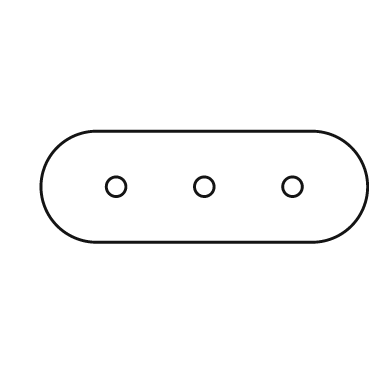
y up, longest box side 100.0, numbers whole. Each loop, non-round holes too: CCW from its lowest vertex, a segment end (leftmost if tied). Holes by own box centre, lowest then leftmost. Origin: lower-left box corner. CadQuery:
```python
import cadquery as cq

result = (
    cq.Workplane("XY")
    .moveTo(17.0, 0.0)
    .lineTo(83.0, 0.0)
    .threePointArc((100.0, 17.0), (83.0, 34.0))
    .lineTo(17.0, 34.0)
    .threePointArc((0.0, 17.0), (17.0, 0.0))
    .close()
    .moveTo(23.0, 17.0)
    .circle(3.0)
    .moveTo(50.0, 17.0)
    .circle(3.0)
    .moveTo(77.0, 17.0)
    .circle(3.0)
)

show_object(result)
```